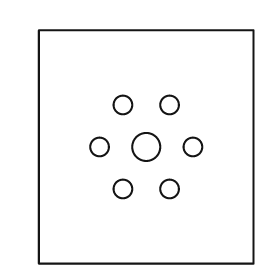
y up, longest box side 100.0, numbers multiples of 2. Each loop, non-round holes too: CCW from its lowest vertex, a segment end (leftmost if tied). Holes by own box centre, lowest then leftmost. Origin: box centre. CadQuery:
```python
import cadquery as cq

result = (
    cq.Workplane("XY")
    .moveTo(-46.0, -50.0)
    .lineTo(46.0, -50.0)
    .lineTo(46.0, 50.0)
    .lineTo(-46.0, 50.0)
    .close()
    .moveTo(-10.0, -18.0)
    .circle(4.0)
    .moveTo(10.0, -18.0)
    .circle(4.0)
    .moveTo(-20.0, 0.0)
    .circle(4.0)
    .moveTo(0.0, 0.0)
    .circle(6.0)
    .moveTo(20.0, 0.0)
    .circle(4.0)
    .moveTo(-10.0, 18.0)
    .circle(4.0)
    .moveTo(10.0, 18.0)
    .circle(4.0)
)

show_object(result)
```